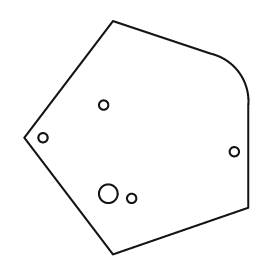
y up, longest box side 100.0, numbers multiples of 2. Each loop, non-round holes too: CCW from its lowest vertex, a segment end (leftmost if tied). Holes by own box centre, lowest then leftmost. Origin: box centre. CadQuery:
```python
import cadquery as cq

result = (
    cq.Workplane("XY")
    .moveTo(-10.0, -50.0)
    .lineTo(48.0, -30.0)
    .lineTo(48.0, 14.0)
    .threePointArc((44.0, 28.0), (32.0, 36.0))
    .lineTo(-10.0, 50.0)
    .lineTo(-48.0, 0.0)
    .close()
    .moveTo(-2.0, -26.0)
    .circle(2.0)
    .moveTo(-12.0, -24.0)
    .circle(4.0)
    .moveTo(42.0, -6.0)
    .circle(2.0)
    .moveTo(-40.0, 0.0)
    .circle(2.0)
    .moveTo(-14.0, 14.0)
    .circle(2.0)
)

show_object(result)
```